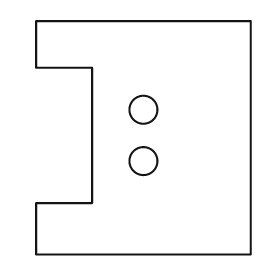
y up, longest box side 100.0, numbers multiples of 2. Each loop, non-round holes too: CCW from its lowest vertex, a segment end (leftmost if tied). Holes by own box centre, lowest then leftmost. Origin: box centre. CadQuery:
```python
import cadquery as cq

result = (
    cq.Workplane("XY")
    .moveTo(-46.0, -50.0)
    .lineTo(46.0, -50.0)
    .lineTo(46.0, 50.0)
    .lineTo(-46.0, 50.0)
    .lineTo(-46.0, 30.0)
    .lineTo(-22.0, 30.0)
    .lineTo(-22.0, -28.0)
    .lineTo(-46.0, -28.0)
    .close()
    .moveTo(0.0, -10.0)
    .circle(6.0)
    .moveTo(0.0, 12.0)
    .circle(6.0)
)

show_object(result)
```